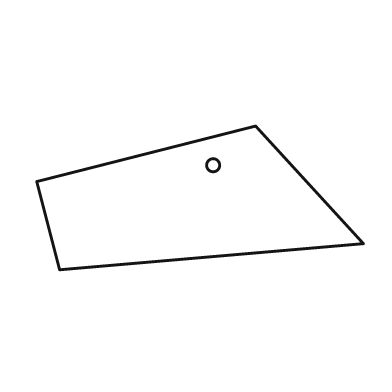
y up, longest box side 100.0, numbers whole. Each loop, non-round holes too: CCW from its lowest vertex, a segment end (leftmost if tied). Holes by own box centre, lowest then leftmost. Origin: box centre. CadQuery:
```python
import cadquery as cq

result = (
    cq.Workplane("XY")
    .moveTo(-43.0, -22.0)
    .lineTo(50.0, -14.0)
    .lineTo(17.0, 22.0)
    .lineTo(-50.0, 5.0)
    .close()
    .moveTo(4.0, 10.0)
    .circle(2.0)
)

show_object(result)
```